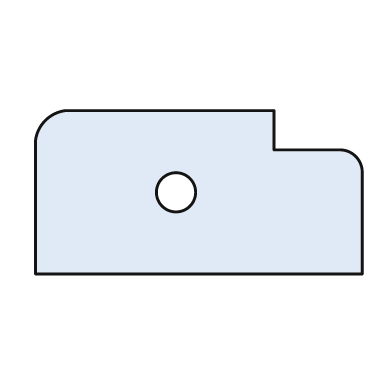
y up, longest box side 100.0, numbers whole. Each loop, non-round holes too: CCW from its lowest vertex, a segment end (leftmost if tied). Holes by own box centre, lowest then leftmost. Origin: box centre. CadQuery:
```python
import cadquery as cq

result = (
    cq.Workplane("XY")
    .moveTo(-50.0, -25.0)
    .lineTo(50.0, -25.0)
    .lineTo(50.0, 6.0)
    .threePointArc((48.0, 11.0), (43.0, 13.0))
    .lineTo(23.0, 13.0)
    .lineTo(23.0, 25.0)
    .lineTo(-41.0, 25.0)
    .threePointArc((-47.0, 22.0), (-50.0, 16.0))
    .close()
    .moveTo(-7.0, 0.0)
    .circle(6.0)
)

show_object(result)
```